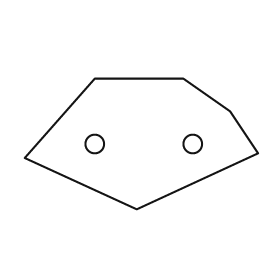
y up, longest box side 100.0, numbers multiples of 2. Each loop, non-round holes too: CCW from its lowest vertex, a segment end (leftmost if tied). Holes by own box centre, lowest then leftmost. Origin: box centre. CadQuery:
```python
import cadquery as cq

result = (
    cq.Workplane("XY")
    .moveTo(-2.0, -28.0)
    .lineTo(50.0, -4.0)
    .lineTo(38.0, 14.0)
    .lineTo(18.0, 28.0)
    .lineTo(-20.0, 28.0)
    .lineTo(-50.0, -6.0)
    .close()
    .moveTo(-20.0, 0.0)
    .circle(4.0)
    .moveTo(22.0, 0.0)
    .circle(4.0)
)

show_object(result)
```